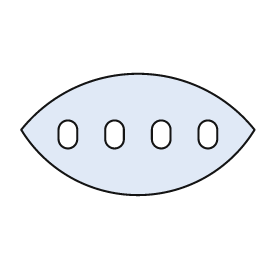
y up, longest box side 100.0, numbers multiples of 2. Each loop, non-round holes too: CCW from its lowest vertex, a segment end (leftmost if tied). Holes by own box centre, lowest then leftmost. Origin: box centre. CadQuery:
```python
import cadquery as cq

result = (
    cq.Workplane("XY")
    .moveTo(-50.0, 2.0)
    .threePointArc((0.0, -26.0), (50.0, 2.0))
    .threePointArc((0.0, 26.0), (-50.0, 2.0))
    .close()
    .moveTo(-34.0, -2.0)
    .threePointArc((-30.0, -6.0), (-26.0, -2.0))
    .lineTo(-26.0, 2.0)
    .threePointArc((-30.0, 6.0), (-34.0, 2.0))
    .close()
    .moveTo(-14.0, -2.0)
    .threePointArc((-10.0, -6.0), (-6.0, -2.0))
    .lineTo(-6.0, 2.0)
    .threePointArc((-10.0, 6.0), (-14.0, 2.0))
    .close()
    .moveTo(6.0, -2.0)
    .threePointArc((10.0, -6.0), (14.0, -2.0))
    .lineTo(14.0, 2.0)
    .threePointArc((10.0, 6.0), (6.0, 2.0))
    .close()
    .moveTo(26.0, -2.0)
    .threePointArc((30.0, -6.0), (34.0, -2.0))
    .lineTo(34.0, 2.0)
    .threePointArc((30.0, 6.0), (26.0, 2.0))
    .close()
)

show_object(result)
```